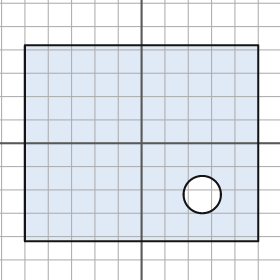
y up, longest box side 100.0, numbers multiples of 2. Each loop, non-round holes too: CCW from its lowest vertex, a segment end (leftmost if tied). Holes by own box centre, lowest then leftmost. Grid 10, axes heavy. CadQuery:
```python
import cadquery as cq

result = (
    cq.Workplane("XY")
    .moveTo(-50.0, -42.0)
    .lineTo(50.0, -42.0)
    .lineTo(50.0, 42.0)
    .lineTo(-50.0, 42.0)
    .close()
    .moveTo(26.0, -22.0)
    .circle(8.0)
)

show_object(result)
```